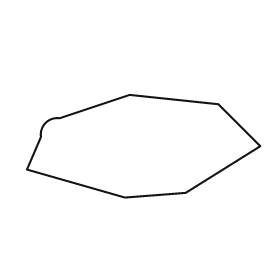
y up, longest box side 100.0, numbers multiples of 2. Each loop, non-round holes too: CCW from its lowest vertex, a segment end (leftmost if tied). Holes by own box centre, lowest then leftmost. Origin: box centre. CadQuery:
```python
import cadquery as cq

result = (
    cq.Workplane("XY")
    .moveTo(-8.0, -22.0)
    .lineTo(18.0, -20.0)
    .lineTo(50.0, 0.0)
    .lineTo(32.0, 18.0)
    .lineTo(-6.0, 22.0)
    .lineTo(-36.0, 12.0)
    .threePointArc((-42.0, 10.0), (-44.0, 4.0))
    .lineTo(-50.0, -10.0)
    .close()
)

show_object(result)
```